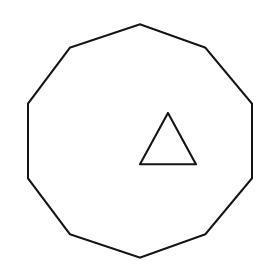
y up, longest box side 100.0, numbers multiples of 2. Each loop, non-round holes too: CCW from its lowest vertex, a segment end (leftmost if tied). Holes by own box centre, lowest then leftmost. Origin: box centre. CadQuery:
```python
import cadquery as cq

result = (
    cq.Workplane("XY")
    .moveTo(0.0, -50.0)
    .lineTo(28.0, -40.0)
    .lineTo(48.0, -16.0)
    .lineTo(48.0, 16.0)
    .lineTo(28.0, 40.0)
    .lineTo(0.0, 50.0)
    .lineTo(-30.0, 40.0)
    .lineTo(-48.0, 16.0)
    .lineTo(-48.0, -16.0)
    .lineTo(-30.0, -40.0)
    .close()
    .moveTo(0.0, -10.0)
    .lineTo(24.0, -10.0)
    .lineTo(12.0, 12.0)
    .close()
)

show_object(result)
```